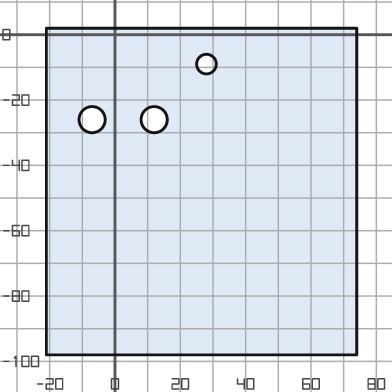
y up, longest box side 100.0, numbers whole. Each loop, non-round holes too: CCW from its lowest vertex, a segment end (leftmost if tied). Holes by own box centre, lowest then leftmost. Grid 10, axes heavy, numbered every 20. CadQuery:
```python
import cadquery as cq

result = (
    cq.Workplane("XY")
    .moveTo(-21.0, -98.0)
    .lineTo(74.0, -98.0)
    .lineTo(74.0, 2.0)
    .lineTo(-21.0, 2.0)
    .close()
    .moveTo(-7.0, -26.0)
    .circle(4.0)
    .moveTo(12.0, -26.0)
    .circle(4.0)
    .moveTo(28.0, -9.0)
    .circle(3.0)
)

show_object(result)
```